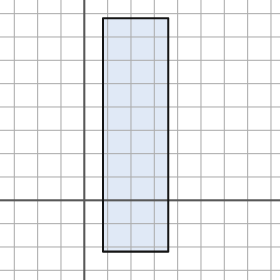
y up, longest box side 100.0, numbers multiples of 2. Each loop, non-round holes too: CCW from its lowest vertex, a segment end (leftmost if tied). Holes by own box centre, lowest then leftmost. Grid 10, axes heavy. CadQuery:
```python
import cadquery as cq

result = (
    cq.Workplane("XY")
    .moveTo(8.0, -22.0)
    .lineTo(36.0, -22.0)
    .lineTo(36.0, 78.0)
    .lineTo(8.0, 78.0)
    .close()
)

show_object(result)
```